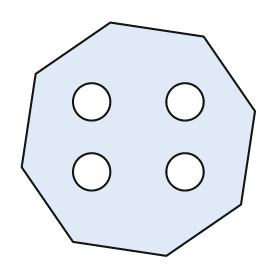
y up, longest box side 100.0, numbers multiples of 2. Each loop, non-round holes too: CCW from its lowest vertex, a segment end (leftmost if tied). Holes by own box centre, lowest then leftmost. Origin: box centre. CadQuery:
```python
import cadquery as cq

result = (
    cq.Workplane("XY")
    .moveTo(12.0, -50.0)
    .lineTo(44.0, -28.0)
    .lineTo(50.0, 12.0)
    .lineTo(28.0, 44.0)
    .lineTo(-12.0, 50.0)
    .lineTo(-44.0, 28.0)
    .lineTo(-50.0, -12.0)
    .lineTo(-28.0, -44.0)
    .close()
    .moveTo(-20.0, -14.0)
    .circle(8.0)
    .moveTo(20.0, -14.0)
    .circle(8.0)
    .moveTo(-20.0, 16.0)
    .circle(8.0)
    .moveTo(20.0, 16.0)
    .circle(8.0)
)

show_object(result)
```